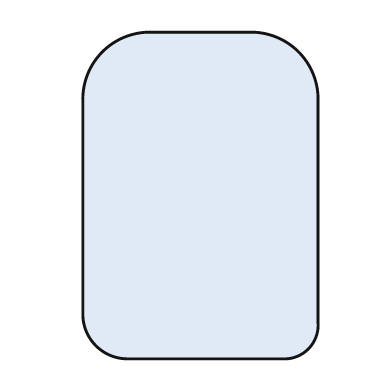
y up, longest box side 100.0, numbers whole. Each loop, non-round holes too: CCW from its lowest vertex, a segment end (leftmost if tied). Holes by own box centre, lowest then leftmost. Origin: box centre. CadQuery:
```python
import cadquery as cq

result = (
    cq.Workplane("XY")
    .moveTo(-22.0, -50.0)
    .lineTo(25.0, -50.0)
    .threePointArc((33.0, -47.0), (36.0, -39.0))
    .lineTo(36.0, 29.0)
    .threePointArc((30.0, 44.0), (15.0, 50.0))
    .lineTo(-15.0, 50.0)
    .threePointArc((-30.0, 44.0), (-36.0, 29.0))
    .lineTo(-36.0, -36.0)
    .threePointArc((-32.0, -46.0), (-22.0, -50.0))
    .close()
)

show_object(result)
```